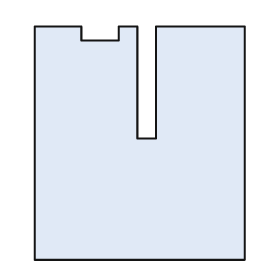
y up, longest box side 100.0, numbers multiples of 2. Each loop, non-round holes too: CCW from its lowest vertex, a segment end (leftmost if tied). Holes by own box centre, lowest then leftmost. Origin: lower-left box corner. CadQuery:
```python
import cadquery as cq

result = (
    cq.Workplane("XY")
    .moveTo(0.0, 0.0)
    .lineTo(90.0, 0.0)
    .lineTo(90.0, 100.0)
    .lineTo(52.0, 100.0)
    .lineTo(52.0, 52.0)
    .lineTo(44.0, 52.0)
    .lineTo(44.0, 100.0)
    .lineTo(36.0, 100.0)
    .lineTo(36.0, 94.0)
    .lineTo(20.0, 94.0)
    .lineTo(20.0, 100.0)
    .lineTo(0.0, 100.0)
    .close()
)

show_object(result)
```